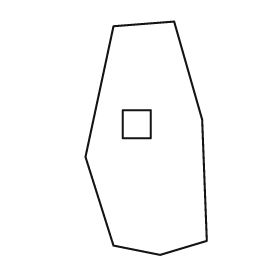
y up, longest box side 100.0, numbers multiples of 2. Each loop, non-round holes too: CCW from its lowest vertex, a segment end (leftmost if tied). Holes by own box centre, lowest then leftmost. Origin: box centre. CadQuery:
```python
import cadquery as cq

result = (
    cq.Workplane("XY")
    .moveTo(6.0, -50.0)
    .lineTo(26.0, -44.0)
    .lineTo(24.0, 8.0)
    .lineTo(12.0, 50.0)
    .lineTo(-14.0, 48.0)
    .lineTo(-26.0, -8.0)
    .lineTo(-14.0, -46.0)
    .close()
    .moveTo(-10.0, 0.0)
    .lineTo(2.0, 0.0)
    .lineTo(2.0, 12.0)
    .lineTo(-10.0, 12.0)
    .close()
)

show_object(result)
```